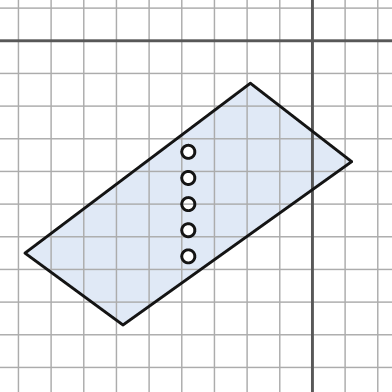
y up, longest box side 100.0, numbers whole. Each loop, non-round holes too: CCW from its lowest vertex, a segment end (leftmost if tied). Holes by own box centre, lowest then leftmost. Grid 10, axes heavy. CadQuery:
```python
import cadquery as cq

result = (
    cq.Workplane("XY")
    .moveTo(-58.0, -87.0)
    .lineTo(12.0, -37.0)
    .lineTo(-19.0, -13.0)
    .lineTo(-88.0, -65.0)
    .close()
    .moveTo(-38.0, -66.0)
    .circle(2.0)
    .moveTo(-38.0, -58.0)
    .circle(2.0)
    .moveTo(-38.0, -50.0)
    .circle(2.0)
    .moveTo(-38.0, -42.0)
    .circle(2.0)
    .moveTo(-38.0, -34.0)
    .circle(2.0)
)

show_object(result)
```